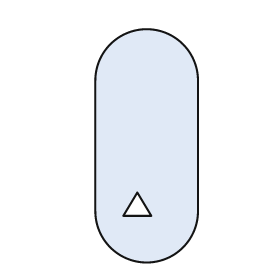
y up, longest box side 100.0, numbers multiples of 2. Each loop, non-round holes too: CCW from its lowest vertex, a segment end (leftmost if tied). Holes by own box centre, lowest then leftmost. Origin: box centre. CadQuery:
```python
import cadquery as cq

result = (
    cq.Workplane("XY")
    .moveTo(-22.0, -28.0)
    .threePointArc((0.0, -50.0), (22.0, -28.0))
    .lineTo(22.0, 28.0)
    .threePointArc((0.0, 50.0), (-22.0, 28.0))
    .close()
    .moveTo(-10.0, -30.0)
    .lineTo(2.0, -30.0)
    .lineTo(-4.0, -20.0)
    .close()
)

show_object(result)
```